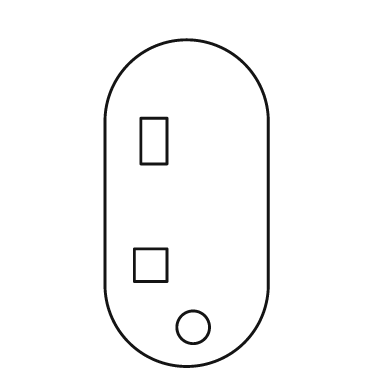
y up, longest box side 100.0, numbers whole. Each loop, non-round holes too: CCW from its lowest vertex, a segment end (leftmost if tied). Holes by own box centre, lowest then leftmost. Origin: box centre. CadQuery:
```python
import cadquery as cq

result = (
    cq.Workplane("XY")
    .moveTo(-25.0, -25.0)
    .threePointArc((0.0, -50.0), (25.0, -25.0))
    .lineTo(25.0, 25.0)
    .threePointArc((0.0, 50.0), (-25.0, 25.0))
    .close()
    .moveTo(2.0, -38.0)
    .circle(5.0)
    .moveTo(-16.0, -24.0)
    .lineTo(-6.0, -24.0)
    .lineTo(-6.0, -14.0)
    .lineTo(-16.0, -14.0)
    .close()
    .moveTo(-14.0, 12.0)
    .lineTo(-6.0, 12.0)
    .lineTo(-6.0, 26.0)
    .lineTo(-14.0, 26.0)
    .close()
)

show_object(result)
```